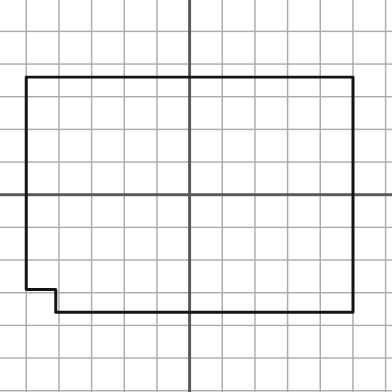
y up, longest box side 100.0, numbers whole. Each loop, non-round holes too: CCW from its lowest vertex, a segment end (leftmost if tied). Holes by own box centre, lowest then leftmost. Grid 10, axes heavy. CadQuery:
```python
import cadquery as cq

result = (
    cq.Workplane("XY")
    .moveTo(-41.0, -36.0)
    .lineTo(50.0, -36.0)
    .lineTo(50.0, 36.0)
    .lineTo(-50.0, 36.0)
    .lineTo(-50.0, -29.0)
    .lineTo(-41.0, -29.0)
    .close()
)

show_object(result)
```